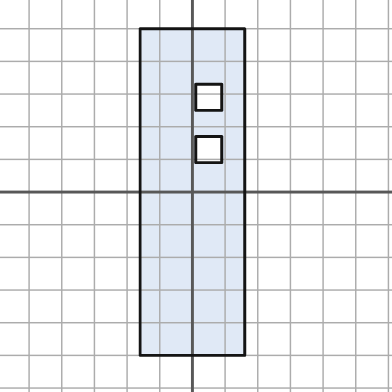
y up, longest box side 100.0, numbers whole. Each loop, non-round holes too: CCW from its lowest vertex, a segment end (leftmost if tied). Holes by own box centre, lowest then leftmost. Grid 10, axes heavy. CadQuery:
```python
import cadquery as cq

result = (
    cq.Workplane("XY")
    .moveTo(-16.0, -50.0)
    .lineTo(16.0, -50.0)
    .lineTo(16.0, 50.0)
    .lineTo(-16.0, 50.0)
    .close()
    .moveTo(1.0, 9.0)
    .lineTo(9.0, 9.0)
    .lineTo(9.0, 17.0)
    .lineTo(1.0, 17.0)
    .close()
    .moveTo(1.0, 25.0)
    .lineTo(9.0, 25.0)
    .lineTo(9.0, 33.0)
    .lineTo(1.0, 33.0)
    .close()
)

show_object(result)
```